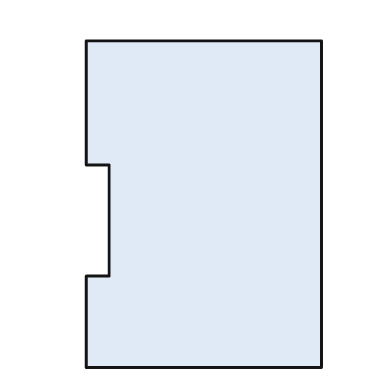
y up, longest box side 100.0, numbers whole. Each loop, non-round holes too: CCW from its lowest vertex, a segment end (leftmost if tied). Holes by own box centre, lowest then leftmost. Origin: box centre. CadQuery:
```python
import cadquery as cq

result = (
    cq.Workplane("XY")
    .moveTo(-36.0, -50.0)
    .lineTo(36.0, -50.0)
    .lineTo(36.0, 50.0)
    .lineTo(-36.0, 50.0)
    .lineTo(-36.0, 12.0)
    .lineTo(-29.0, 12.0)
    .lineTo(-29.0, -22.0)
    .lineTo(-36.0, -22.0)
    .close()
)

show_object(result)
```